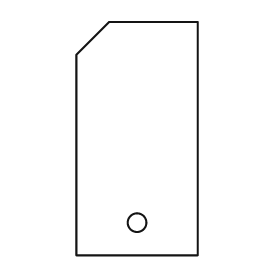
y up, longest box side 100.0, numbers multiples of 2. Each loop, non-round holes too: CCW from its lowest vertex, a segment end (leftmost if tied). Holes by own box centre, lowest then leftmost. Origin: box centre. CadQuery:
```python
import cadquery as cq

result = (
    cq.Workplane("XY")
    .moveTo(-26.0, -50.0)
    .lineTo(26.0, -50.0)
    .lineTo(26.0, 50.0)
    .lineTo(-12.0, 50.0)
    .lineTo(-26.0, 36.0)
    .close()
    .moveTo(0.0, -36.0)
    .circle(4.0)
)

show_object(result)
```